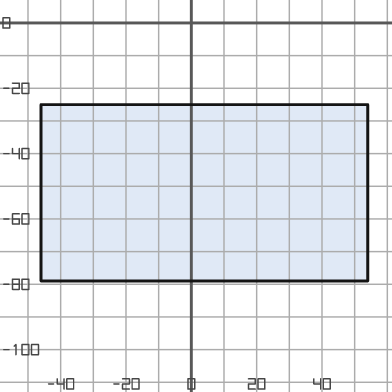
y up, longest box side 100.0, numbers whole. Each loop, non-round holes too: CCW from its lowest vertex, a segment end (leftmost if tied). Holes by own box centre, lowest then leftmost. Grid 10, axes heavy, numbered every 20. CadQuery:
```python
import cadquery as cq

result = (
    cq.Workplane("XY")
    .moveTo(-46.0, -79.0)
    .lineTo(54.0, -79.0)
    .lineTo(54.0, -25.0)
    .lineTo(-46.0, -25.0)
    .close()
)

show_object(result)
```